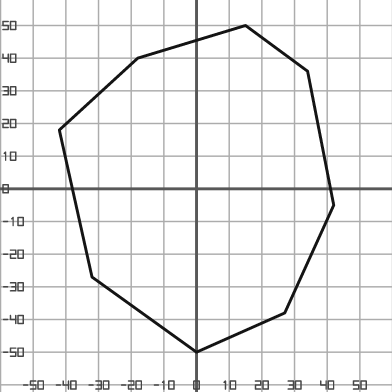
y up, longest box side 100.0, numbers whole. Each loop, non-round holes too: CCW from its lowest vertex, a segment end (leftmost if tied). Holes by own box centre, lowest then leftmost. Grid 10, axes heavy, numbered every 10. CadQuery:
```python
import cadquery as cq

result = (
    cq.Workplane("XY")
    .moveTo(0.0, -50.0)
    .lineTo(27.0, -38.0)
    .lineTo(42.0, -5.0)
    .lineTo(34.0, 36.0)
    .lineTo(15.0, 50.0)
    .lineTo(-18.0, 40.0)
    .lineTo(-42.0, 18.0)
    .lineTo(-32.0, -27.0)
    .close()
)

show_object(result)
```